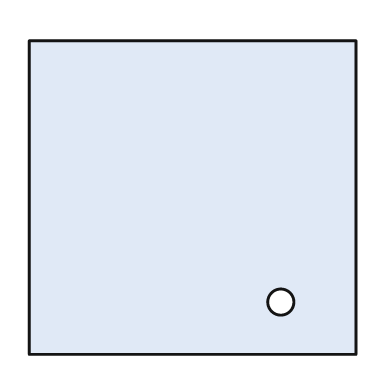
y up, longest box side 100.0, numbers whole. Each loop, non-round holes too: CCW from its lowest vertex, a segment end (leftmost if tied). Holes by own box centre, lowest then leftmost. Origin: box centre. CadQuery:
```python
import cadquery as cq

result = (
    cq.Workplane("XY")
    .moveTo(-50.0, -48.0)
    .lineTo(50.0, -48.0)
    .lineTo(50.0, 48.0)
    .lineTo(-50.0, 48.0)
    .close()
    .moveTo(27.0, -32.0)
    .circle(4.0)
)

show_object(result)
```